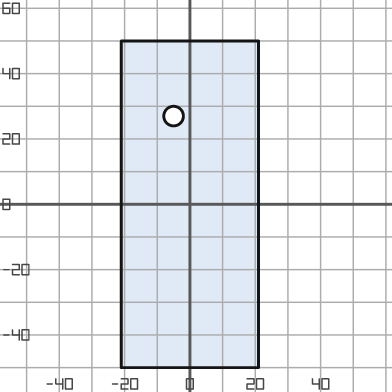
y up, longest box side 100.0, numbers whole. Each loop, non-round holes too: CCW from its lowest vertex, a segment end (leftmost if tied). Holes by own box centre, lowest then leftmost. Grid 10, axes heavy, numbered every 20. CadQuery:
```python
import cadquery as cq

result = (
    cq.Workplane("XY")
    .moveTo(-21.0, -50.0)
    .lineTo(21.0, -50.0)
    .lineTo(21.0, 50.0)
    .lineTo(-21.0, 50.0)
    .close()
    .moveTo(-5.0, 27.0)
    .circle(3.0)
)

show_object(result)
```